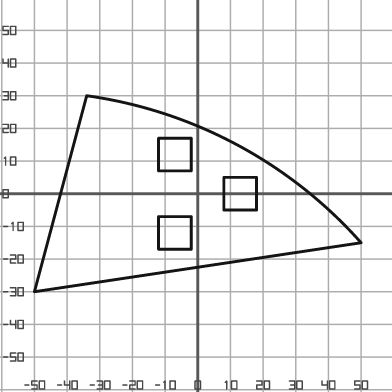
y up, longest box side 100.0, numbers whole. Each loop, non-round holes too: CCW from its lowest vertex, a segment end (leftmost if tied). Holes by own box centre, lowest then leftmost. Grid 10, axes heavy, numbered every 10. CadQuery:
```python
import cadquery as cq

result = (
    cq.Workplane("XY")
    .moveTo(-50.0, -30.0)
    .lineTo(50.0, -15.0)
    .threePointArc((12.0, 15.0), (-34.0, 30.0))
    .close()
    .moveTo(-12.0, -17.0)
    .lineTo(-2.0, -17.0)
    .lineTo(-2.0, -7.0)
    .lineTo(-12.0, -7.0)
    .close()
    .moveTo(8.0, -5.0)
    .lineTo(18.0, -5.0)
    .lineTo(18.0, 5.0)
    .lineTo(8.0, 5.0)
    .close()
    .moveTo(-12.0, 7.0)
    .lineTo(-2.0, 7.0)
    .lineTo(-2.0, 17.0)
    .lineTo(-12.0, 17.0)
    .close()
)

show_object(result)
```